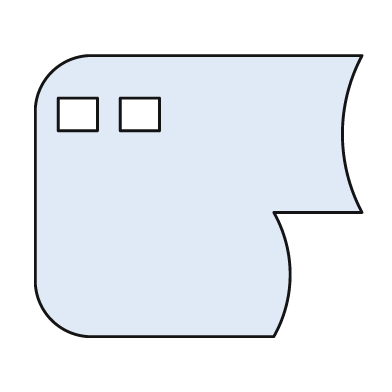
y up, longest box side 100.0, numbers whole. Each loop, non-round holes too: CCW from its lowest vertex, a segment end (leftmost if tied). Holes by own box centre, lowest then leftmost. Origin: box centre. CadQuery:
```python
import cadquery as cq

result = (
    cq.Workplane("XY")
    .moveTo(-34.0, -43.0)
    .lineTo(23.0, -43.0)
    .threePointArc((28.0, -24.0), (23.0, -5.0))
    .lineTo(50.0, -5.0)
    .threePointArc((44.0, 19.0), (50.0, 43.0))
    .lineTo(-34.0, 43.0)
    .threePointArc((-45.0, 38.0), (-50.0, 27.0))
    .lineTo(-50.0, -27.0)
    .threePointArc((-45.0, -38.0), (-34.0, -43.0))
    .close()
    .moveTo(-43.0, 20.0)
    .lineTo(-31.0, 20.0)
    .lineTo(-31.0, 30.0)
    .lineTo(-43.0, 30.0)
    .close()
    .moveTo(-24.0, 20.0)
    .lineTo(-12.0, 20.0)
    .lineTo(-12.0, 30.0)
    .lineTo(-24.0, 30.0)
    .close()
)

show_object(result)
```